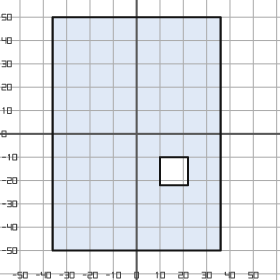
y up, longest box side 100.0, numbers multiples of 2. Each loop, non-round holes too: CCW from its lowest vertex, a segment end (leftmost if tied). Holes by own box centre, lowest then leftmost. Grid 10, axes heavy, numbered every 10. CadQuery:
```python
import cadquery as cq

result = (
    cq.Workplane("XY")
    .moveTo(-36.0, -50.0)
    .lineTo(36.0, -50.0)
    .lineTo(36.0, 50.0)
    .lineTo(-36.0, 50.0)
    .close()
    .moveTo(10.0, -22.0)
    .lineTo(22.0, -22.0)
    .lineTo(22.0, -10.0)
    .lineTo(10.0, -10.0)
    .close()
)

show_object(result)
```